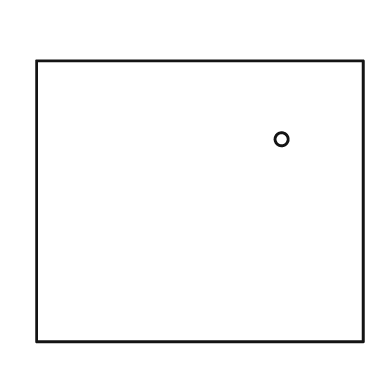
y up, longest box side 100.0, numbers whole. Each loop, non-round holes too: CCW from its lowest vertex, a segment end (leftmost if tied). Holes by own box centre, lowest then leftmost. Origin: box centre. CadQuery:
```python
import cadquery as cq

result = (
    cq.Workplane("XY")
    .moveTo(-50.0, -43.0)
    .lineTo(50.0, -43.0)
    .lineTo(50.0, 43.0)
    .lineTo(-50.0, 43.0)
    .close()
    .moveTo(25.0, 19.0)
    .circle(2.0)
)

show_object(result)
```